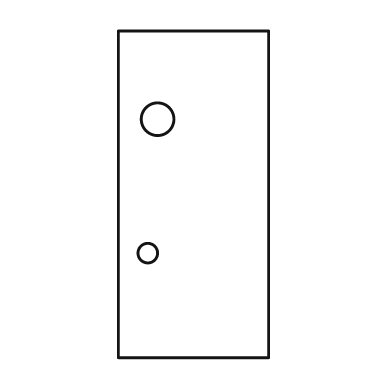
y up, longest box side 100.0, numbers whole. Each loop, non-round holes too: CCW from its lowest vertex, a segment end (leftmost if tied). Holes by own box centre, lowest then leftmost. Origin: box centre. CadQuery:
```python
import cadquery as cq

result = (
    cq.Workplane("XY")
    .moveTo(-23.0, -50.0)
    .lineTo(23.0, -50.0)
    .lineTo(23.0, 50.0)
    .lineTo(-23.0, 50.0)
    .close()
    .moveTo(-14.0, -18.0)
    .circle(3.0)
    .moveTo(-11.0, 23.0)
    .circle(5.0)
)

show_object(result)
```